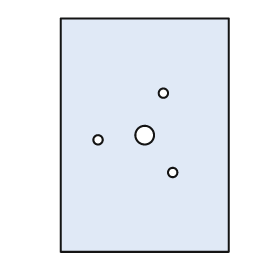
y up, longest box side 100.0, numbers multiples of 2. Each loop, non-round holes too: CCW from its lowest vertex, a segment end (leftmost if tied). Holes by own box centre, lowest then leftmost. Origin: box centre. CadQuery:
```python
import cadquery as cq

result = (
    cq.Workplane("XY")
    .moveTo(-36.0, -50.0)
    .lineTo(36.0, -50.0)
    .lineTo(36.0, 50.0)
    .lineTo(-36.0, 50.0)
    .close()
    .moveTo(12.0, -16.0)
    .circle(2.0)
    .moveTo(-20.0, -2.0)
    .circle(2.0)
    .moveTo(0.0, 0.0)
    .circle(4.0)
    .moveTo(8.0, 18.0)
    .circle(2.0)
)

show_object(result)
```